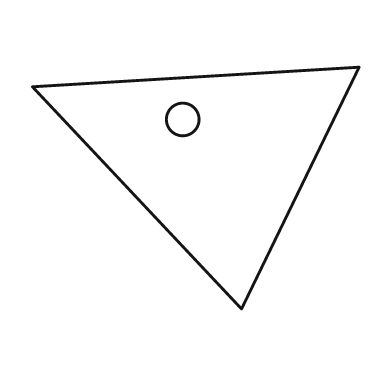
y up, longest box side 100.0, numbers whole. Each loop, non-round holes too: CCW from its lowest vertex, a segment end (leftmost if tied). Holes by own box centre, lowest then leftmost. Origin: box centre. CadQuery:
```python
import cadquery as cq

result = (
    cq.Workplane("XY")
    .moveTo(14.0, -37.0)
    .lineTo(50.0, 37.0)
    .lineTo(-50.0, 31.0)
    .close()
    .moveTo(-4.0, 21.0)
    .circle(5.0)
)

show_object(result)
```